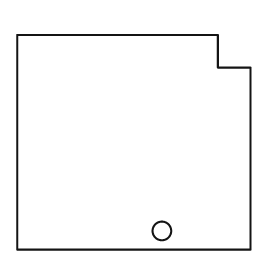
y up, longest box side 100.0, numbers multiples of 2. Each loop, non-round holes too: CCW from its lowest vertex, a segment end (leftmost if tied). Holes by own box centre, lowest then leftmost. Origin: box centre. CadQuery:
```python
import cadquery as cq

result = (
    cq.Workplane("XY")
    .moveTo(-50.0, -46.0)
    .lineTo(50.0, -46.0)
    .lineTo(50.0, 32.0)
    .lineTo(36.0, 32.0)
    .lineTo(36.0, 46.0)
    .lineTo(-50.0, 46.0)
    .close()
    .moveTo(12.0, -38.0)
    .circle(4.0)
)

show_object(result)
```